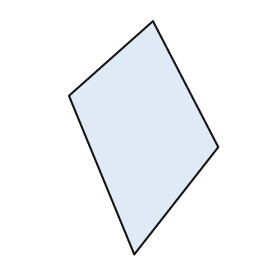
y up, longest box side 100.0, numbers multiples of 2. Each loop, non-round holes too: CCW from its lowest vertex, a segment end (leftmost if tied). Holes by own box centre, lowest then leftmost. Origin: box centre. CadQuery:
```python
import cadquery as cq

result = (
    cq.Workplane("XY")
    .moveTo(-4.0, -50.0)
    .lineTo(32.0, -4.0)
    .lineTo(4.0, 50.0)
    .lineTo(-32.0, 18.0)
    .close()
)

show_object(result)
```